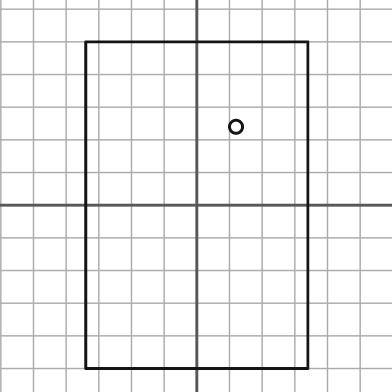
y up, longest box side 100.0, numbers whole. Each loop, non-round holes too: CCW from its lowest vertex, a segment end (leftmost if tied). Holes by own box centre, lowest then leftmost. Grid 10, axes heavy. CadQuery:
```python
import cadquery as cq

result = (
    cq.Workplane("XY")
    .moveTo(-34.0, -50.0)
    .lineTo(34.0, -50.0)
    .lineTo(34.0, 50.0)
    .lineTo(-34.0, 50.0)
    .close()
    .moveTo(12.0, 24.0)
    .circle(2.0)
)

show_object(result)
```